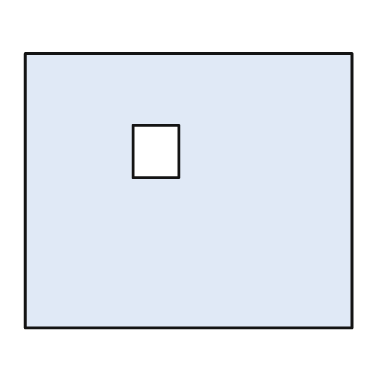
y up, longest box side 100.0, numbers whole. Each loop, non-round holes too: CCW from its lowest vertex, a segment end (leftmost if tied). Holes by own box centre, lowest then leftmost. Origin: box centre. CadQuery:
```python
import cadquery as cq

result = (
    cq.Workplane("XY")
    .moveTo(-50.0, -42.0)
    .lineTo(50.0, -42.0)
    .lineTo(50.0, 42.0)
    .lineTo(-50.0, 42.0)
    .close()
    .moveTo(-17.0, 4.0)
    .lineTo(-3.0, 4.0)
    .lineTo(-3.0, 20.0)
    .lineTo(-17.0, 20.0)
    .close()
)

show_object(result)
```